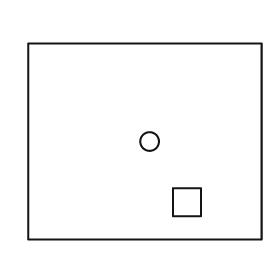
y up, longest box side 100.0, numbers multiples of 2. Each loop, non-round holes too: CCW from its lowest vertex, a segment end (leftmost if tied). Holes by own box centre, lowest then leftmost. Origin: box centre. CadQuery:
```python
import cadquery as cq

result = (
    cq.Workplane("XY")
    .moveTo(-50.0, -42.0)
    .lineTo(50.0, -42.0)
    .lineTo(50.0, 42.0)
    .lineTo(-50.0, 42.0)
    .close()
    .moveTo(12.0, -32.0)
    .lineTo(24.0, -32.0)
    .lineTo(24.0, -20.0)
    .lineTo(12.0, -20.0)
    .close()
    .moveTo(2.0, 0.0)
    .circle(4.0)
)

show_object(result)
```